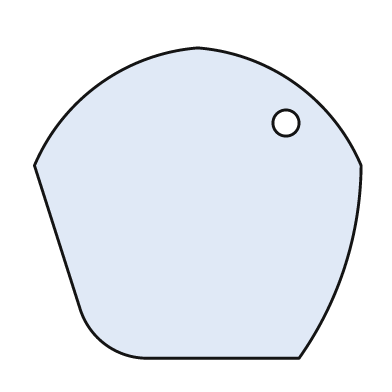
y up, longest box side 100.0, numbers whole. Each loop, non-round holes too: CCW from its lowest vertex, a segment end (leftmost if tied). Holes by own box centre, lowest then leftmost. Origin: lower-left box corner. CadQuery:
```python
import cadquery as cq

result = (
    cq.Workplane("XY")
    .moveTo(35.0, 0.0)
    .lineTo(81.0, 0.0)
    .threePointArc((95.0, 28.0), (100.0, 59.0))
    .threePointArc((80.0, 84.0), (50.0, 95.0))
    .threePointArc((20.0, 84.0), (0.0, 59.0))
    .lineTo(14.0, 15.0)
    .threePointArc((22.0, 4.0), (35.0, 0.0))
    .close()
    .moveTo(77.0, 72.0)
    .circle(4.0)
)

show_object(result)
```